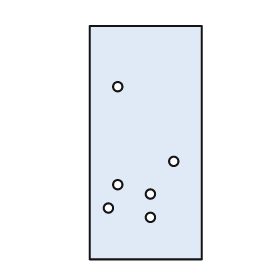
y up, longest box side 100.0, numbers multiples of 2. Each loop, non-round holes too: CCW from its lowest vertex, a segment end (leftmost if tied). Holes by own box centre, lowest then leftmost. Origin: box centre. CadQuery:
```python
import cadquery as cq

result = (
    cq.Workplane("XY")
    .moveTo(-24.0, -50.0)
    .lineTo(24.0, -50.0)
    .lineTo(24.0, 50.0)
    .lineTo(-24.0, 50.0)
    .close()
    .moveTo(2.0, -32.0)
    .circle(2.0)
    .moveTo(-16.0, -28.0)
    .circle(2.0)
    .moveTo(2.0, -22.0)
    .circle(2.0)
    .moveTo(-12.0, -18.0)
    .circle(2.0)
    .moveTo(12.0, -8.0)
    .circle(2.0)
    .moveTo(-12.0, 24.0)
    .circle(2.0)
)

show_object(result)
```